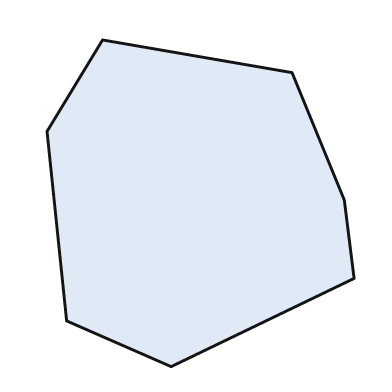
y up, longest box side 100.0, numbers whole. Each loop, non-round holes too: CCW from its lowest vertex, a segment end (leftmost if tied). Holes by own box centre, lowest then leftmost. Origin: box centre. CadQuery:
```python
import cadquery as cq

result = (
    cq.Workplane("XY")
    .moveTo(-9.0, -50.0)
    .lineTo(47.0, -23.0)
    .lineTo(44.0, 1.0)
    .lineTo(28.0, 40.0)
    .lineTo(-30.0, 50.0)
    .lineTo(-47.0, 22.0)
    .lineTo(-41.0, -36.0)
    .close()
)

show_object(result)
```